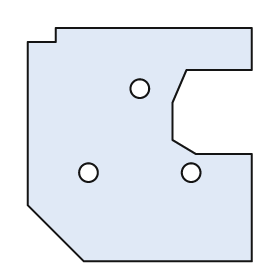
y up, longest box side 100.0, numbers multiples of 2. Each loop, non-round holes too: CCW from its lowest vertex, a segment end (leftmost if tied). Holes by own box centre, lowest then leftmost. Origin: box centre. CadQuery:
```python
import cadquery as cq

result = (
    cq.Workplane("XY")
    .moveTo(-24.0, -50.0)
    .lineTo(48.0, -50.0)
    .lineTo(48.0, -4.0)
    .lineTo(24.0, -4.0)
    .lineTo(14.0, 2.0)
    .lineTo(14.0, 18.0)
    .lineTo(20.0, 32.0)
    .lineTo(48.0, 32.0)
    .lineTo(48.0, 50.0)
    .lineTo(-36.0, 50.0)
    .lineTo(-36.0, 44.0)
    .lineTo(-48.0, 44.0)
    .lineTo(-48.0, -26.0)
    .close()
    .moveTo(-22.0, -12.0)
    .circle(4.0)
    .moveTo(22.0, -12.0)
    .circle(4.0)
    .moveTo(0.0, 24.0)
    .circle(4.0)
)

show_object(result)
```